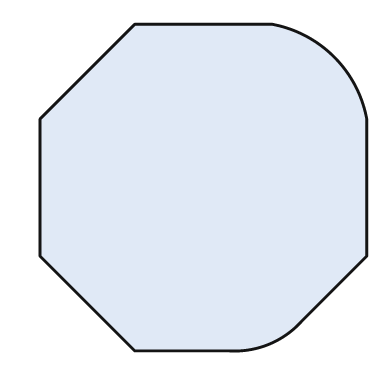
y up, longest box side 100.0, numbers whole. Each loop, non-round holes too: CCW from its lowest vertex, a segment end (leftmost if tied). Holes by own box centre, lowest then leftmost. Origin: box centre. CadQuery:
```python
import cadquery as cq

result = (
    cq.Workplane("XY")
    .moveTo(-21.0, -50.0)
    .lineTo(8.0, -50.0)
    .threePointArc((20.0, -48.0), (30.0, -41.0))
    .lineTo(50.0, -21.0)
    .lineTo(50.0, 21.0)
    .threePointArc((40.0, 40.0), (21.0, 50.0))
    .lineTo(-21.0, 50.0)
    .lineTo(-50.0, 21.0)
    .lineTo(-50.0, -21.0)
    .close()
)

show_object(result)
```